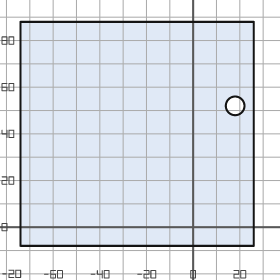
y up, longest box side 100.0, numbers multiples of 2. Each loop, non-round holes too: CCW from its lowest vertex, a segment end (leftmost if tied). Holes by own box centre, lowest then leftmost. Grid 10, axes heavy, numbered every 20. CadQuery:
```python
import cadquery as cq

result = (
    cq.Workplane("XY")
    .moveTo(-74.0, -8.0)
    .lineTo(26.0, -8.0)
    .lineTo(26.0, 88.0)
    .lineTo(-74.0, 88.0)
    .close()
    .moveTo(18.0, 52.0)
    .circle(4.0)
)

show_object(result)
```